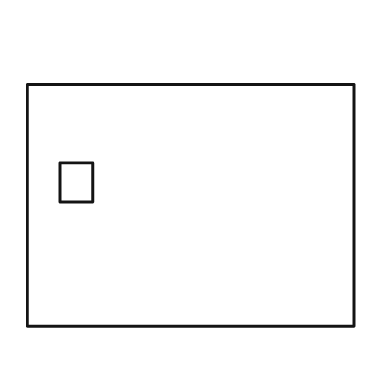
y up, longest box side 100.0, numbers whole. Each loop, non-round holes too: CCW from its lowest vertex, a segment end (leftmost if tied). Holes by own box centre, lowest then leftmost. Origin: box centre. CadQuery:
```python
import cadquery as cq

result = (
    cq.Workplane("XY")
    .moveTo(-50.0, -37.0)
    .lineTo(50.0, -37.0)
    .lineTo(50.0, 37.0)
    .lineTo(-50.0, 37.0)
    .close()
    .moveTo(-40.0, 1.0)
    .lineTo(-30.0, 1.0)
    .lineTo(-30.0, 13.0)
    .lineTo(-40.0, 13.0)
    .close()
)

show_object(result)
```